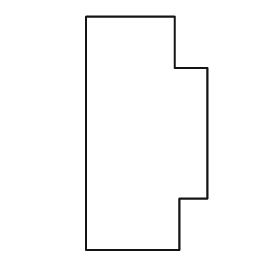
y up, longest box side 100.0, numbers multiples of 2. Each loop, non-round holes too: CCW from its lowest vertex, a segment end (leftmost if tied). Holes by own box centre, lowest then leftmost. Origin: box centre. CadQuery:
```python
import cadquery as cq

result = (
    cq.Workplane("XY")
    .moveTo(-26.0, -50.0)
    .lineTo(14.0, -50.0)
    .lineTo(14.0, -28.0)
    .lineTo(26.0, -28.0)
    .lineTo(26.0, 28.0)
    .lineTo(12.0, 28.0)
    .lineTo(12.0, 50.0)
    .lineTo(-26.0, 50.0)
    .close()
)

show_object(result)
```